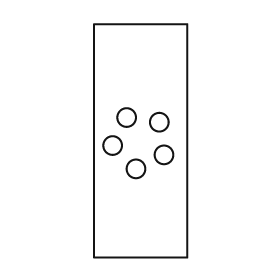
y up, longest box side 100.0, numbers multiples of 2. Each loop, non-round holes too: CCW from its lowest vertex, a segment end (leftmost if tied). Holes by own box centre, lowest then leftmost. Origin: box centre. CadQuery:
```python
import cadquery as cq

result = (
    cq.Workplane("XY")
    .moveTo(-20.0, -50.0)
    .lineTo(20.0, -50.0)
    .lineTo(20.0, 50.0)
    .lineTo(-20.0, 50.0)
    .close()
    .moveTo(-2.0, -12.0)
    .circle(4.0)
    .moveTo(10.0, -6.0)
    .circle(4.0)
    .moveTo(-12.0, -2.0)
    .circle(4.0)
    .moveTo(8.0, 8.0)
    .circle(4.0)
    .moveTo(-6.0, 10.0)
    .circle(4.0)
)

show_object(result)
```